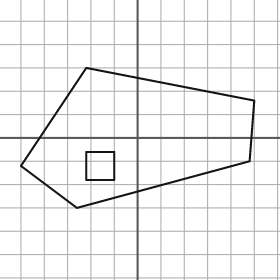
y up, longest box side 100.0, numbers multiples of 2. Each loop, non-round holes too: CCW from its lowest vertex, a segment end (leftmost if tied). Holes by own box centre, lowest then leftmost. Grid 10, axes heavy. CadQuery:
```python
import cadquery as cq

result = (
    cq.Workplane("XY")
    .moveTo(-26.0, -30.0)
    .lineTo(48.0, -10.0)
    .lineTo(50.0, 16.0)
    .lineTo(-22.0, 30.0)
    .lineTo(-50.0, -12.0)
    .close()
    .moveTo(-22.0, -18.0)
    .lineTo(-10.0, -18.0)
    .lineTo(-10.0, -6.0)
    .lineTo(-22.0, -6.0)
    .close()
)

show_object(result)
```